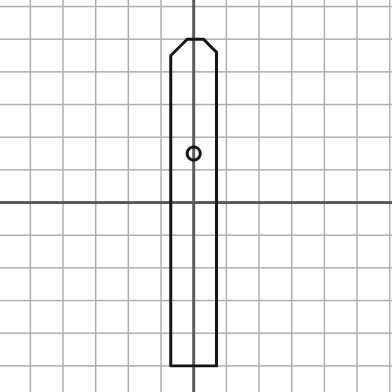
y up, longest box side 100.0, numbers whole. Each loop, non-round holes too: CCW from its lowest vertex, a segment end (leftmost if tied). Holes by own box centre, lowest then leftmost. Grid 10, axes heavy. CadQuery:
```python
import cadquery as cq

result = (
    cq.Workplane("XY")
    .moveTo(-7.0, -50.0)
    .lineTo(7.0, -50.0)
    .lineTo(7.0, 46.0)
    .lineTo(3.0, 50.0)
    .lineTo(-2.0, 50.0)
    .lineTo(-7.0, 45.0)
    .close()
    .moveTo(0.0, 15.0)
    .circle(2.0)
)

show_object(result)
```